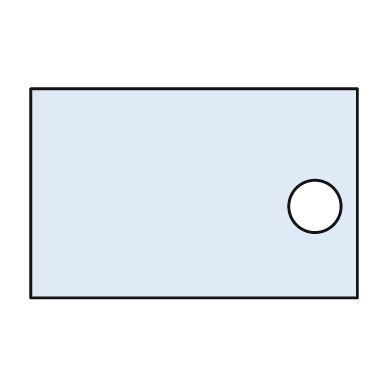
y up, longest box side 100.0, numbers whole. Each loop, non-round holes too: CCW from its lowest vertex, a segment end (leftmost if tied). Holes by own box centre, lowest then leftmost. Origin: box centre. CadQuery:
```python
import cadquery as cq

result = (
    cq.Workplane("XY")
    .moveTo(-50.0, -32.0)
    .lineTo(50.0, -32.0)
    .lineTo(50.0, 32.0)
    .lineTo(-50.0, 32.0)
    .close()
    .moveTo(37.0, -4.0)
    .circle(8.0)
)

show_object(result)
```